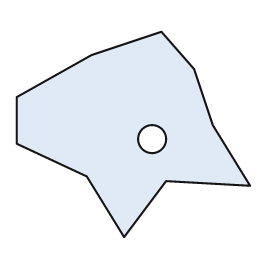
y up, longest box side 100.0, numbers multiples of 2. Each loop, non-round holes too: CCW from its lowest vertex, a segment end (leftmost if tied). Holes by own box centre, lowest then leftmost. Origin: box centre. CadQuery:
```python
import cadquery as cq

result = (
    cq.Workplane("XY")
    .moveTo(-4.0, -44.0)
    .lineTo(14.0, -20.0)
    .lineTo(50.0, -22.0)
    .lineTo(34.0, 4.0)
    .lineTo(26.0, 28.0)
    .lineTo(12.0, 44.0)
    .lineTo(-18.0, 34.0)
    .lineTo(-50.0, 16.0)
    .lineTo(-50.0, -4.0)
    .lineTo(-20.0, -18.0)
    .close()
    .moveTo(8.0, -2.0)
    .circle(6.0)
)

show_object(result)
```